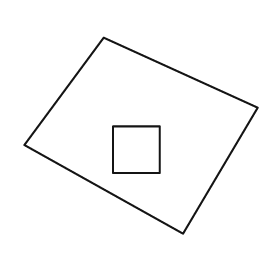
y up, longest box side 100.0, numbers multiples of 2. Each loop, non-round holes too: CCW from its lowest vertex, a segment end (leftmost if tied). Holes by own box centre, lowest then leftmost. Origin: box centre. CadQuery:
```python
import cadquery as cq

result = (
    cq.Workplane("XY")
    .moveTo(18.0, -42.0)
    .lineTo(50.0, 12.0)
    .lineTo(-16.0, 42.0)
    .lineTo(-50.0, -4.0)
    .close()
    .moveTo(-12.0, -16.0)
    .lineTo(8.0, -16.0)
    .lineTo(8.0, 4.0)
    .lineTo(-12.0, 4.0)
    .close()
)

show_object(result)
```